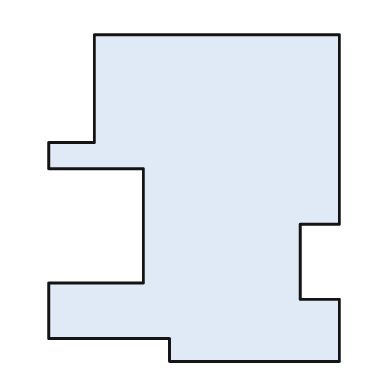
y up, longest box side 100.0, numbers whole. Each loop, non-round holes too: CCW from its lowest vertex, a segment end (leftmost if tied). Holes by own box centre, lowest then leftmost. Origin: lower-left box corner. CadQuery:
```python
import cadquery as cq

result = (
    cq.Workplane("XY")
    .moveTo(37.0, 0.0)
    .lineTo(89.0, 0.0)
    .lineTo(89.0, 19.0)
    .lineTo(77.0, 19.0)
    .lineTo(77.0, 42.0)
    .lineTo(89.0, 42.0)
    .lineTo(89.0, 100.0)
    .lineTo(14.0, 100.0)
    .lineTo(14.0, 67.0)
    .lineTo(0.0, 67.0)
    .lineTo(0.0, 59.0)
    .lineTo(29.0, 59.0)
    .lineTo(29.0, 24.0)
    .lineTo(0.0, 24.0)
    .lineTo(0.0, 7.0)
    .lineTo(37.0, 7.0)
    .close()
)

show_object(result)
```